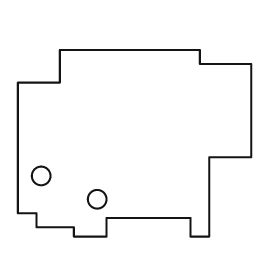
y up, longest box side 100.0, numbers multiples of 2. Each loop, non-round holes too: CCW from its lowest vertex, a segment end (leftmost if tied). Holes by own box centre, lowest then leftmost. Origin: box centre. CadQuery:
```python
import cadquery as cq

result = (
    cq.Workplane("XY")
    .moveTo(-26.0, -40.0)
    .lineTo(-12.0, -40.0)
    .lineTo(-12.0, -32.0)
    .lineTo(24.0, -32.0)
    .lineTo(24.0, -40.0)
    .lineTo(32.0, -40.0)
    .lineTo(32.0, -6.0)
    .lineTo(50.0, -6.0)
    .lineTo(50.0, 34.0)
    .lineTo(28.0, 34.0)
    .lineTo(28.0, 40.0)
    .lineTo(-32.0, 40.0)
    .lineTo(-32.0, 26.0)
    .lineTo(-50.0, 26.0)
    .lineTo(-50.0, -30.0)
    .lineTo(-42.0, -30.0)
    .lineTo(-42.0, -36.0)
    .lineTo(-26.0, -36.0)
    .close()
    .moveTo(-16.0, -24.0)
    .circle(4.0)
    .moveTo(-40.0, -14.0)
    .circle(4.0)
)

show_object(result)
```